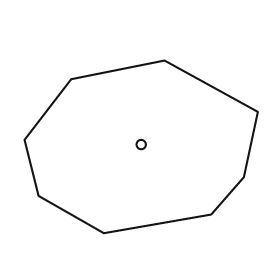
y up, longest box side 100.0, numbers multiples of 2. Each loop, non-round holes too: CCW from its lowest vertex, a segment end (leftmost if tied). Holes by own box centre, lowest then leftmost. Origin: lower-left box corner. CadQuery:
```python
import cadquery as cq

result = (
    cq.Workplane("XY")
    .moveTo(34.0, 0.0)
    .lineTo(80.0, 8.0)
    .lineTo(94.0, 24.0)
    .lineTo(100.0, 52.0)
    .lineTo(60.0, 74.0)
    .lineTo(20.0, 66.0)
    .lineTo(0.0, 40.0)
    .lineTo(6.0, 16.0)
    .close()
    .moveTo(50.0, 38.0)
    .circle(2.0)
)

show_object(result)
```